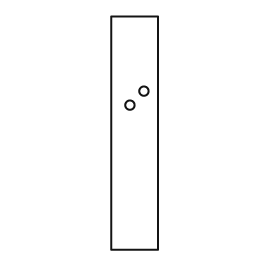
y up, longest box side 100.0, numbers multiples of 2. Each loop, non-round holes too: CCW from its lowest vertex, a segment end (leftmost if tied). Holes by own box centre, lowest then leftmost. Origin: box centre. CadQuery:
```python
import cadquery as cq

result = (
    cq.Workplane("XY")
    .moveTo(-10.0, -50.0)
    .lineTo(10.0, -50.0)
    .lineTo(10.0, 50.0)
    .lineTo(-10.0, 50.0)
    .close()
    .moveTo(-2.0, 12.0)
    .circle(2.0)
    .moveTo(4.0, 18.0)
    .circle(2.0)
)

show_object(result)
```